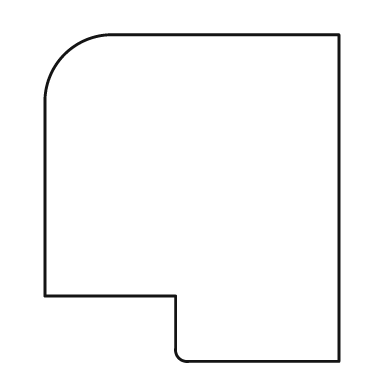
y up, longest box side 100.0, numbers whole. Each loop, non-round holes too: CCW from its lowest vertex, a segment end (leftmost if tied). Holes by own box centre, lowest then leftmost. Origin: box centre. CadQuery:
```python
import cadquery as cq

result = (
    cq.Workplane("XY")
    .moveTo(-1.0, -50.0)
    .lineTo(45.0, -50.0)
    .lineTo(45.0, 50.0)
    .lineTo(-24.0, 50.0)
    .threePointArc((-39.0, 44.0), (-45.0, 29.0))
    .lineTo(-45.0, -30.0)
    .lineTo(-5.0, -30.0)
    .lineTo(-5.0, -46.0)
    .threePointArc((-4.0, -49.0), (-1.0, -50.0))
    .close()
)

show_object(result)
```